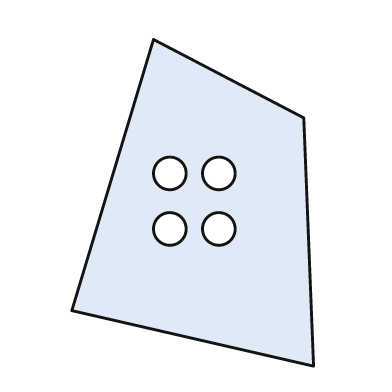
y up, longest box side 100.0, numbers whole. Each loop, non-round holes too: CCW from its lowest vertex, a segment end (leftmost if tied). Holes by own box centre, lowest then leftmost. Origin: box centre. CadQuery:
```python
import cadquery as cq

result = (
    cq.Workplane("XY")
    .moveTo(37.0, -50.0)
    .lineTo(34.0, 26.0)
    .lineTo(-12.0, 50.0)
    .lineTo(-37.0, -33.0)
    .close()
    .moveTo(-7.0, -8.0)
    .circle(5.0)
    .moveTo(8.0, -8.0)
    .circle(5.0)
    .moveTo(-7.0, 9.0)
    .circle(5.0)
    .moveTo(8.0, 9.0)
    .circle(5.0)
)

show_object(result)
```